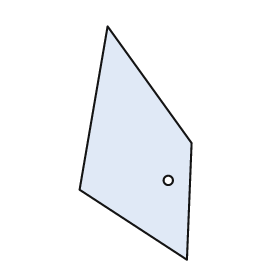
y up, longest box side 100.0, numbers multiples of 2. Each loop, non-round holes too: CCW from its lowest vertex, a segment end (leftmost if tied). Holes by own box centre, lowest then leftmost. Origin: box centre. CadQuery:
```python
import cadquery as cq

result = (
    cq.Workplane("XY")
    .moveTo(22.0, -50.0)
    .lineTo(24.0, 0.0)
    .lineTo(-12.0, 50.0)
    .lineTo(-24.0, -20.0)
    .close()
    .moveTo(14.0, -16.0)
    .circle(2.0)
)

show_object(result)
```